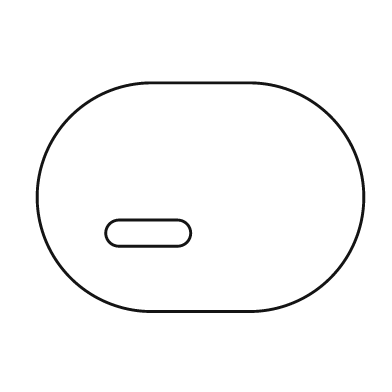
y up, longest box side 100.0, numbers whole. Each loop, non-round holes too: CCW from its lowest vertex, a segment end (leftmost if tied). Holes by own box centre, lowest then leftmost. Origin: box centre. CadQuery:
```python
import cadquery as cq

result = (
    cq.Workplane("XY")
    .moveTo(-15.0, -35.0)
    .lineTo(15.0, -35.0)
    .threePointArc((50.0, 0.0), (15.0, 35.0))
    .lineTo(-15.0, 35.0)
    .threePointArc((-50.0, 0.0), (-15.0, -35.0))
    .close()
    .moveTo(-25.0, -15.0)
    .lineTo(-7.0, -15.0)
    .threePointArc((-3.0, -11.0), (-7.0, -7.0))
    .lineTo(-25.0, -7.0)
    .threePointArc((-29.0, -11.0), (-25.0, -15.0))
    .close()
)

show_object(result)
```